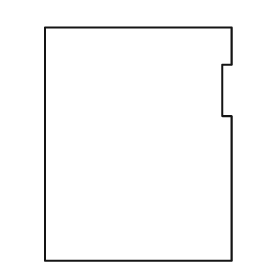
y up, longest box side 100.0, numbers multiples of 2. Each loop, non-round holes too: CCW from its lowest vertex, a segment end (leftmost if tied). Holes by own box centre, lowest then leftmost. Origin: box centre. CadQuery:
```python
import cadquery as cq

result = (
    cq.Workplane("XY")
    .moveTo(-40.0, -50.0)
    .lineTo(40.0, -50.0)
    .lineTo(40.0, 12.0)
    .lineTo(36.0, 12.0)
    .lineTo(36.0, 34.0)
    .lineTo(40.0, 34.0)
    .lineTo(40.0, 50.0)
    .lineTo(-40.0, 50.0)
    .close()
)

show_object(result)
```